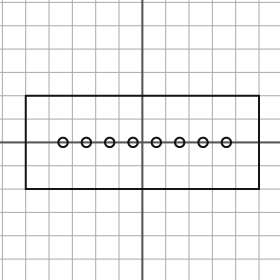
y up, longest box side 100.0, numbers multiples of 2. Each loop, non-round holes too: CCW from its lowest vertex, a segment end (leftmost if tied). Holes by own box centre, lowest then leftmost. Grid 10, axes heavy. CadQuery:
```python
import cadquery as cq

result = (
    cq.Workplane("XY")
    .moveTo(-50.0, -20.0)
    .lineTo(50.0, -20.0)
    .lineTo(50.0, 20.0)
    .lineTo(-50.0, 20.0)
    .close()
    .moveTo(-34.0, 0.0)
    .circle(2.0)
    .moveTo(-24.0, 0.0)
    .circle(2.0)
    .moveTo(-14.0, 0.0)
    .circle(2.0)
    .moveTo(-4.0, 0.0)
    .circle(2.0)
    .moveTo(6.0, 0.0)
    .circle(2.0)
    .moveTo(16.0, 0.0)
    .circle(2.0)
    .moveTo(26.0, 0.0)
    .circle(2.0)
    .moveTo(36.0, 0.0)
    .circle(2.0)
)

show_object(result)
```